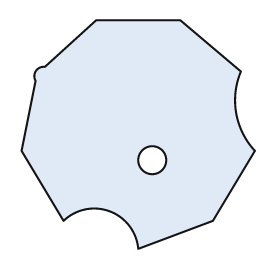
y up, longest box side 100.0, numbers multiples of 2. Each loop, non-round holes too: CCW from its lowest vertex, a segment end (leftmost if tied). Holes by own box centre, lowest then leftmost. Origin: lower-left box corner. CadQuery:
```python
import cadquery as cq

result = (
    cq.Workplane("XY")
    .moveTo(50.0, 0.0)
    .lineTo(82.0, 12.0)
    .lineTo(100.0, 42.0)
    .threePointArc((92.0, 58.0), (94.0, 76.0))
    .lineTo(68.0, 98.0)
    .lineTo(32.0, 98.0)
    .lineTo(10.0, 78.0)
    .threePointArc((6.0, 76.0), (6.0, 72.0))
    .lineTo(0.0, 42.0)
    .lineTo(18.0, 12.0)
    .threePointArc((38.0, 16.0), (50.0, 0.0))
    .close()
    .moveTo(56.0, 38.0)
    .circle(6.0)
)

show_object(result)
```